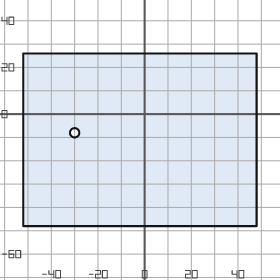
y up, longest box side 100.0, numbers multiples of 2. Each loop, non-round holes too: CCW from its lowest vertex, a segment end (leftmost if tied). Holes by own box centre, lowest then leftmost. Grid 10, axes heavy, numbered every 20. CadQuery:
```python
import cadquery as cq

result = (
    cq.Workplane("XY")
    .moveTo(-52.0, -48.0)
    .lineTo(48.0, -48.0)
    .lineTo(48.0, 26.0)
    .lineTo(-52.0, 26.0)
    .close()
    .moveTo(-30.0, -8.0)
    .circle(2.0)
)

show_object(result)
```